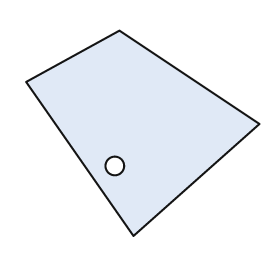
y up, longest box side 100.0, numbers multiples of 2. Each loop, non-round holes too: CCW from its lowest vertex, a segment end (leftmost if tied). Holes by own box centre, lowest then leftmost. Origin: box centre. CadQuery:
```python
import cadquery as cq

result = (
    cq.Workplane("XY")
    .moveTo(-4.0, -44.0)
    .lineTo(50.0, 4.0)
    .lineTo(-10.0, 44.0)
    .lineTo(-50.0, 22.0)
    .close()
    .moveTo(-12.0, -14.0)
    .circle(4.0)
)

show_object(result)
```